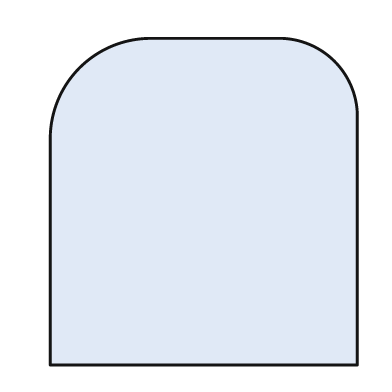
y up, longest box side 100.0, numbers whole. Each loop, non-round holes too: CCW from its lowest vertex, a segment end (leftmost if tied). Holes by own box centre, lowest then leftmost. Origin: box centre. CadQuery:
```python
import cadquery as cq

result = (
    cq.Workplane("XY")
    .moveTo(-47.0, -50.0)
    .lineTo(47.0, -50.0)
    .lineTo(47.0, 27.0)
    .threePointArc((40.0, 43.0), (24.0, 50.0))
    .lineTo(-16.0, 50.0)
    .threePointArc((-38.0, 41.0), (-47.0, 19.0))
    .close()
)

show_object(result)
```